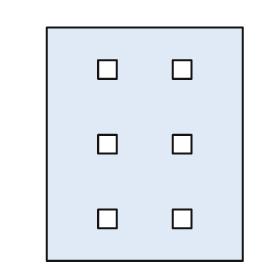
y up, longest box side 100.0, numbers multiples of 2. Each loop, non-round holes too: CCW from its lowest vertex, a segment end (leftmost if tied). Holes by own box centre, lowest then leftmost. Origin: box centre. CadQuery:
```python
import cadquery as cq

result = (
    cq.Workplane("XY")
    .moveTo(-42.0, -50.0)
    .lineTo(42.0, -50.0)
    .lineTo(42.0, 50.0)
    .lineTo(-42.0, 50.0)
    .close()
    .moveTo(-20.0, -36.0)
    .lineTo(-12.0, -36.0)
    .lineTo(-12.0, -28.0)
    .lineTo(-20.0, -28.0)
    .close()
    .moveTo(12.0, -36.0)
    .lineTo(20.0, -36.0)
    .lineTo(20.0, -28.0)
    .lineTo(12.0, -28.0)
    .close()
    .moveTo(-20.0, -4.0)
    .lineTo(-12.0, -4.0)
    .lineTo(-12.0, 4.0)
    .lineTo(-20.0, 4.0)
    .close()
    .moveTo(12.0, -4.0)
    .lineTo(20.0, -4.0)
    .lineTo(20.0, 4.0)
    .lineTo(12.0, 4.0)
    .close()
    .moveTo(-20.0, 28.0)
    .lineTo(-12.0, 28.0)
    .lineTo(-12.0, 36.0)
    .lineTo(-20.0, 36.0)
    .close()
    .moveTo(12.0, 28.0)
    .lineTo(20.0, 28.0)
    .lineTo(20.0, 36.0)
    .lineTo(12.0, 36.0)
    .close()
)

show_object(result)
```